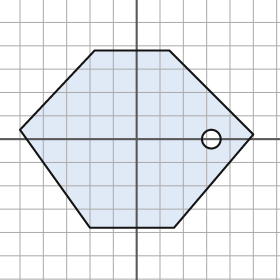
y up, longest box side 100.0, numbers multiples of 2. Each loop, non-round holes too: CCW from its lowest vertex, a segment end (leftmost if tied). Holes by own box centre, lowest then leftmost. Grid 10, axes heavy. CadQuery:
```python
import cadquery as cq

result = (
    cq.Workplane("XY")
    .moveTo(-20.0, -38.0)
    .lineTo(16.0, -38.0)
    .lineTo(50.0, 2.0)
    .lineTo(14.0, 38.0)
    .lineTo(-18.0, 38.0)
    .lineTo(-50.0, 4.0)
    .close()
    .moveTo(32.0, 0.0)
    .circle(4.0)
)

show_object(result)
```